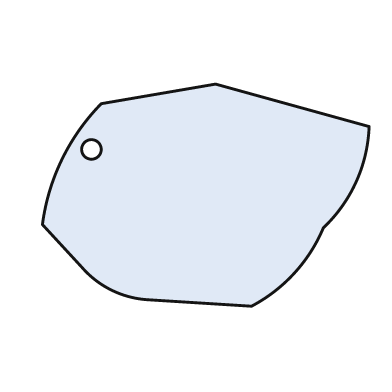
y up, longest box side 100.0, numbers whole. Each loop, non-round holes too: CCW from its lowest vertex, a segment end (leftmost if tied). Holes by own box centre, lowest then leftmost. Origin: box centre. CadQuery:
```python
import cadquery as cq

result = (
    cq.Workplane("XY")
    .moveTo(14.0, -34.0)
    .threePointArc((27.0, -24.0), (36.0, -10.0))
    .threePointArc((46.0, 4.0), (50.0, 21.0))
    .lineTo(3.0, 34.0)
    .lineTo(-32.0, 28.0)
    .threePointArc((-44.0, 11.0), (-50.0, -9.0))
    .lineTo(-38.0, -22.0)
    .threePointArc((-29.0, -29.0), (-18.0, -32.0))
    .close()
    .moveTo(-35.0, 14.0)
    .circle(3.0)
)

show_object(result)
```